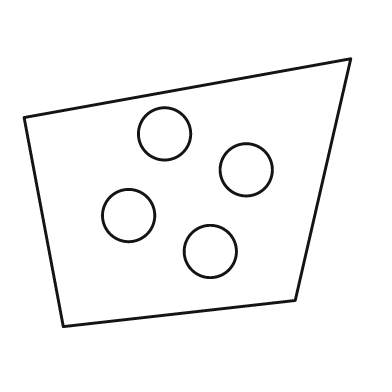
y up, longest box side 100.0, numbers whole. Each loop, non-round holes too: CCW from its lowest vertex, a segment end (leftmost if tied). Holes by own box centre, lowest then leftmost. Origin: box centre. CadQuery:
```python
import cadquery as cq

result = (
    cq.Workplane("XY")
    .moveTo(-38.0, -41.0)
    .lineTo(33.0, -33.0)
    .lineTo(50.0, 41.0)
    .lineTo(-50.0, 23.0)
    .close()
    .moveTo(7.0, -18.0)
    .circle(8.0)
    .moveTo(-18.0, -7.0)
    .circle(8.0)
    .moveTo(18.0, 7.0)
    .circle(8.0)
    .moveTo(-7.0, 18.0)
    .circle(8.0)
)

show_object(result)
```